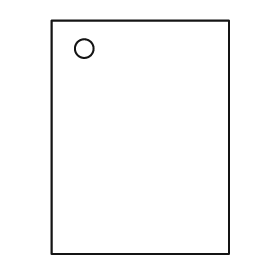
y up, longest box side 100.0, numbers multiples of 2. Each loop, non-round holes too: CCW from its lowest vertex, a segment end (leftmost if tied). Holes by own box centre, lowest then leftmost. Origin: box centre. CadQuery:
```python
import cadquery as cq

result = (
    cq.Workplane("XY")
    .moveTo(-38.0, -50.0)
    .lineTo(38.0, -50.0)
    .lineTo(38.0, 50.0)
    .lineTo(-38.0, 50.0)
    .close()
    .moveTo(-24.0, 38.0)
    .circle(4.0)
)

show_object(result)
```